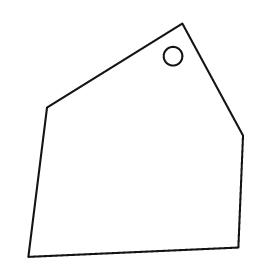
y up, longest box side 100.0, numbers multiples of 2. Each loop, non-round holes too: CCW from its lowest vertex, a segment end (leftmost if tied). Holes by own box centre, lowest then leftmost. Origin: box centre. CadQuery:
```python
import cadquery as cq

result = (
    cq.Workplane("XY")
    .moveTo(-46.0, -50.0)
    .lineTo(44.0, -46.0)
    .lineTo(46.0, 2.0)
    .lineTo(20.0, 50.0)
    .lineTo(-38.0, 14.0)
    .close()
    .moveTo(16.0, 36.0)
    .circle(4.0)
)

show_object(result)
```